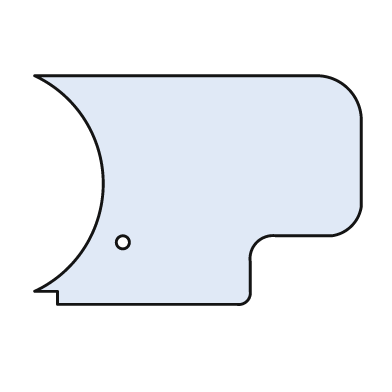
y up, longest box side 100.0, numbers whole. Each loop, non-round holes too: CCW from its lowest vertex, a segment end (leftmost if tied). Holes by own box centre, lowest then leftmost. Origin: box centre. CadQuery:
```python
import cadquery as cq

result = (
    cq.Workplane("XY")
    .moveTo(-43.0, -35.0)
    .lineTo(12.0, -35.0)
    .threePointArc((15.0, -34.0), (16.0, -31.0))
    .lineTo(16.0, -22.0)
    .threePointArc((18.0, -16.0), (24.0, -14.0))
    .lineTo(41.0, -14.0)
    .threePointArc((47.0, -11.0), (50.0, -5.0))
    .lineTo(50.0, 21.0)
    .threePointArc((46.0, 31.0), (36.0, 35.0))
    .lineTo(-50.0, 35.0)
    .threePointArc((-29.0, 2.0), (-50.0, -31.0))
    .lineTo(-43.0, -31.0)
    .close()
    .moveTo(-23.0, -16.0)
    .circle(2.0)
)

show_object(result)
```